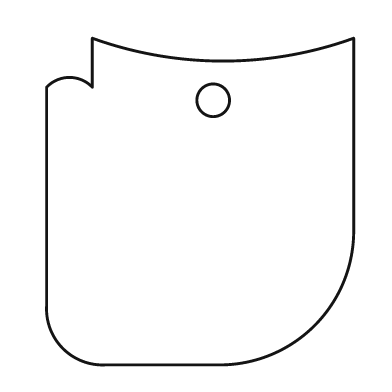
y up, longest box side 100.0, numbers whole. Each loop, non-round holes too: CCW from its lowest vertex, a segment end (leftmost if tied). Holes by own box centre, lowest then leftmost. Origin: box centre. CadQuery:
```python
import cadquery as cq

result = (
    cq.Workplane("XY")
    .moveTo(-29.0, -50.0)
    .lineTo(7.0, -50.0)
    .threePointArc((35.0, -38.0), (47.0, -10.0))
    .lineTo(47.0, 50.0)
    .threePointArc((7.0, 43.0), (-33.0, 50.0))
    .lineTo(-33.0, 35.0)
    .threePointArc((-40.0, 38.0), (-47.0, 35.0))
    .lineTo(-47.0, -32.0)
    .threePointArc((-42.0, -45.0), (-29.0, -50.0))
    .close()
    .moveTo(4.0, 31.0)
    .circle(5.0)
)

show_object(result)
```